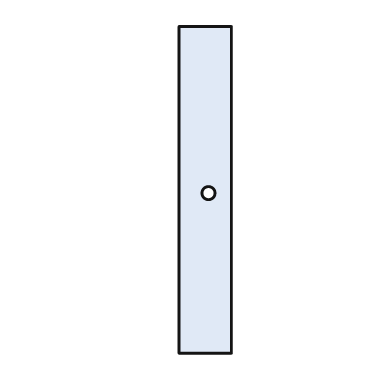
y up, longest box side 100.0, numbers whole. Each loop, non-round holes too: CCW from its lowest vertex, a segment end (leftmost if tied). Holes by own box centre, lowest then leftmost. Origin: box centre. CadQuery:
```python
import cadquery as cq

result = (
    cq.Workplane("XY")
    .moveTo(-8.0, -50.0)
    .lineTo(8.0, -50.0)
    .lineTo(8.0, 50.0)
    .lineTo(-8.0, 50.0)
    .close()
    .moveTo(1.0, -1.0)
    .circle(2.0)
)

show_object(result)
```